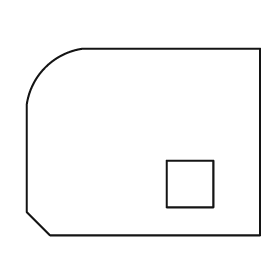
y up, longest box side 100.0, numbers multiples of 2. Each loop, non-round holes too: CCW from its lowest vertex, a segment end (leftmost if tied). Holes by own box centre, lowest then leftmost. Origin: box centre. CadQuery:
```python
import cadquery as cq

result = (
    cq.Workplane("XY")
    .moveTo(-40.0, -40.0)
    .lineTo(50.0, -40.0)
    .lineTo(50.0, 40.0)
    .lineTo(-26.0, 40.0)
    .threePointArc((-42.0, 32.0), (-50.0, 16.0))
    .lineTo(-50.0, -30.0)
    .close()
    .moveTo(10.0, -28.0)
    .lineTo(30.0, -28.0)
    .lineTo(30.0, -8.0)
    .lineTo(10.0, -8.0)
    .close()
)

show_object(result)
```